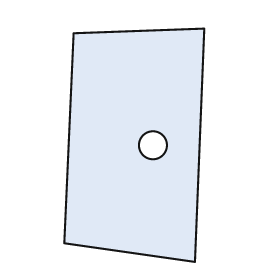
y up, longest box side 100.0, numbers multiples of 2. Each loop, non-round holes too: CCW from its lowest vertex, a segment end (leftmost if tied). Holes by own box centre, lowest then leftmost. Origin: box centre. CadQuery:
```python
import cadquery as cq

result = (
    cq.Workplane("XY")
    .moveTo(26.0, -50.0)
    .lineTo(30.0, 50.0)
    .lineTo(-26.0, 48.0)
    .lineTo(-30.0, -42.0)
    .close()
    .moveTo(8.0, 0.0)
    .circle(6.0)
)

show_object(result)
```